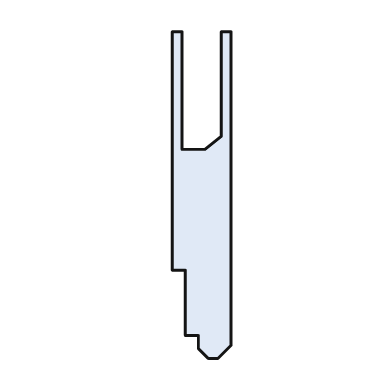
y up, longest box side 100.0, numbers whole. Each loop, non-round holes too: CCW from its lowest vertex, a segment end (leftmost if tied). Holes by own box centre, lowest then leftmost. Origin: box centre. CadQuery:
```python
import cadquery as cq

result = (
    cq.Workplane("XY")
    .moveTo(2.0, -50.0)
    .lineTo(5.0, -50.0)
    .lineTo(9.0, -46.0)
    .lineTo(9.0, 50.0)
    .lineTo(6.0, 50.0)
    .lineTo(6.0, 18.0)
    .lineTo(1.0, 14.0)
    .lineTo(-6.0, 14.0)
    .lineTo(-6.0, 50.0)
    .lineTo(-9.0, 50.0)
    .lineTo(-9.0, -23.0)
    .lineTo(-5.0, -23.0)
    .lineTo(-5.0, -43.0)
    .lineTo(-1.0, -43.0)
    .lineTo(-1.0, -47.0)
    .close()
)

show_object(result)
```